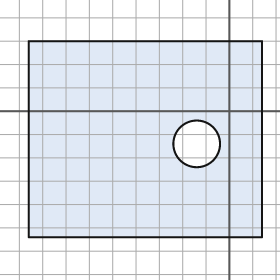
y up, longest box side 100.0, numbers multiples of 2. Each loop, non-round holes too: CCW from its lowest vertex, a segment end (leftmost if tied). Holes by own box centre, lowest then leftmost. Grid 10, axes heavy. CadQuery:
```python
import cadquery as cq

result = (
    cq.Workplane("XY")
    .moveTo(-86.0, -54.0)
    .lineTo(14.0, -54.0)
    .lineTo(14.0, 30.0)
    .lineTo(-86.0, 30.0)
    .close()
    .moveTo(-14.0, -14.0)
    .circle(10.0)
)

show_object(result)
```